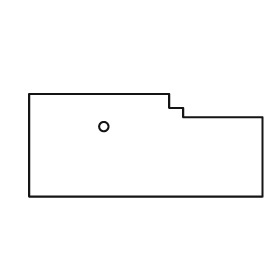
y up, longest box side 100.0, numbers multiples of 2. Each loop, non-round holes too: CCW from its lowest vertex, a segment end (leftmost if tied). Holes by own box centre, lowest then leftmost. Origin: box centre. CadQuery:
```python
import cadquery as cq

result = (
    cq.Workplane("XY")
    .moveTo(-50.0, -22.0)
    .lineTo(50.0, -22.0)
    .lineTo(50.0, 12.0)
    .lineTo(16.0, 12.0)
    .lineTo(16.0, 16.0)
    .lineTo(10.0, 16.0)
    .lineTo(10.0, 22.0)
    .lineTo(-50.0, 22.0)
    .close()
    .moveTo(-18.0, 8.0)
    .circle(2.0)
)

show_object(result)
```